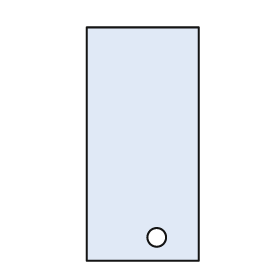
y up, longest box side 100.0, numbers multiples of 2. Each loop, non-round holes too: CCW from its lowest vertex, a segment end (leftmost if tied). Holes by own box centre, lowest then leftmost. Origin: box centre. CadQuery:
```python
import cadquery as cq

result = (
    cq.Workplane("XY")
    .moveTo(-24.0, -50.0)
    .lineTo(24.0, -50.0)
    .lineTo(24.0, 50.0)
    .lineTo(-24.0, 50.0)
    .close()
    .moveTo(6.0, -40.0)
    .circle(4.0)
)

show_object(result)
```